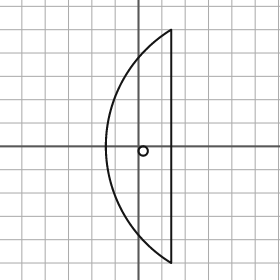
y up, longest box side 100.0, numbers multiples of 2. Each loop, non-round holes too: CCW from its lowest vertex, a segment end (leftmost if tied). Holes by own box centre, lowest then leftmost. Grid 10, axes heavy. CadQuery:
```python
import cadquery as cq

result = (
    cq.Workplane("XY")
    .moveTo(14.0, -50.0)
    .lineTo(14.0, 50.0)
    .threePointArc((-14.0, 0.0), (14.0, -50.0))
    .close()
    .moveTo(2.0, -2.0)
    .circle(2.0)
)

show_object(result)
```